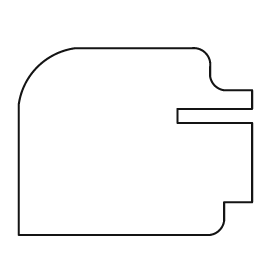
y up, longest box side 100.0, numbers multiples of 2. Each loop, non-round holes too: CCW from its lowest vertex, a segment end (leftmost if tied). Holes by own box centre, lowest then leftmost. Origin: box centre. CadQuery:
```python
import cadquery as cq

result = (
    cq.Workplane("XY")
    .moveTo(-50.0, -40.0)
    .lineTo(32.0, -40.0)
    .threePointArc((36.0, -38.0), (38.0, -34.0))
    .lineTo(38.0, -26.0)
    .lineTo(50.0, -26.0)
    .lineTo(50.0, 8.0)
    .lineTo(18.0, 8.0)
    .lineTo(18.0, 14.0)
    .lineTo(50.0, 14.0)
    .lineTo(50.0, 22.0)
    .lineTo(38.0, 22.0)
    .threePointArc((34.0, 24.0), (32.0, 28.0))
    .lineTo(32.0, 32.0)
    .threePointArc((30.0, 38.0), (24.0, 40.0))
    .lineTo(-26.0, 40.0)
    .threePointArc((-42.0, 32.0), (-50.0, 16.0))
    .close()
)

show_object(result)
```